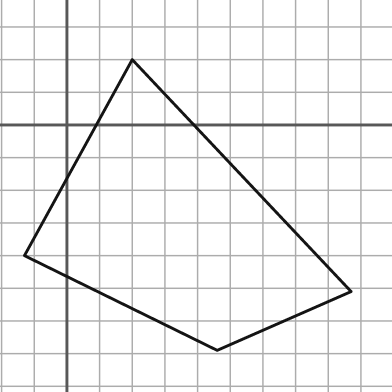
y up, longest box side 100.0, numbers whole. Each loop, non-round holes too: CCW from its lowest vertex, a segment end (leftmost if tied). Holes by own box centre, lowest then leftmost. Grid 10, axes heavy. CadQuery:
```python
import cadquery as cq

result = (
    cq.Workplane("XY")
    .moveTo(46.0, -69.0)
    .lineTo(87.0, -51.0)
    .lineTo(20.0, 20.0)
    .lineTo(-13.0, -40.0)
    .close()
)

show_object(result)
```